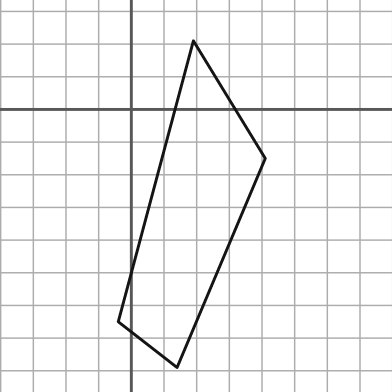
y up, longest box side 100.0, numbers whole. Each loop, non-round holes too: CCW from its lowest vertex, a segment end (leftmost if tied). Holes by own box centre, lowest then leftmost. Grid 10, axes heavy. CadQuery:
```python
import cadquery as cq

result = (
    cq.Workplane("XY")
    .moveTo(14.0, -79.0)
    .lineTo(41.0, -15.0)
    .lineTo(19.0, 21.0)
    .lineTo(-4.0, -65.0)
    .close()
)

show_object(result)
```